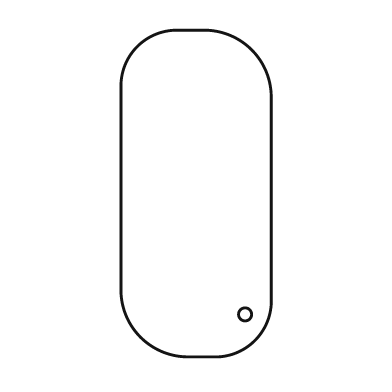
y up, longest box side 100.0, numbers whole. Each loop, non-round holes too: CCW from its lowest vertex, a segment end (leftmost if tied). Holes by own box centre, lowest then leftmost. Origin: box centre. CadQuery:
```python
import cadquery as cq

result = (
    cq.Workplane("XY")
    .moveTo(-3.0, -50.0)
    .lineTo(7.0, -50.0)
    .threePointArc((18.0, -45.0), (23.0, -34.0))
    .lineTo(23.0, 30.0)
    .threePointArc((17.0, 44.0), (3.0, 50.0))
    .lineTo(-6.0, 50.0)
    .threePointArc((-18.0, 45.0), (-23.0, 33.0))
    .lineTo(-23.0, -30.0)
    .threePointArc((-17.0, -44.0), (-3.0, -50.0))
    .close()
    .moveTo(15.0, -37.0)
    .circle(2.0)
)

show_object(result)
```